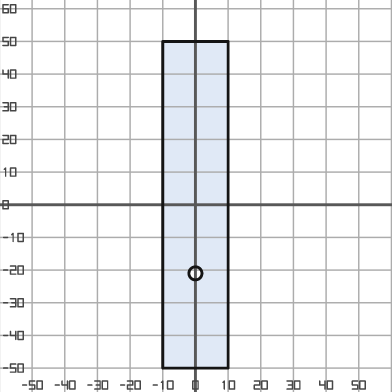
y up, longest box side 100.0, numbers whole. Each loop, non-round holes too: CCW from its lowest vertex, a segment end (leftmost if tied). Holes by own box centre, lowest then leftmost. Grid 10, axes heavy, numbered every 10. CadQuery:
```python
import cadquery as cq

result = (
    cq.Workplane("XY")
    .moveTo(-10.0, -50.0)
    .lineTo(10.0, -50.0)
    .lineTo(10.0, 50.0)
    .lineTo(-10.0, 50.0)
    .close()
    .moveTo(0.0, -21.0)
    .circle(2.0)
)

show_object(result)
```